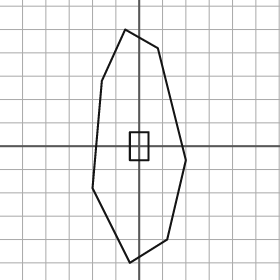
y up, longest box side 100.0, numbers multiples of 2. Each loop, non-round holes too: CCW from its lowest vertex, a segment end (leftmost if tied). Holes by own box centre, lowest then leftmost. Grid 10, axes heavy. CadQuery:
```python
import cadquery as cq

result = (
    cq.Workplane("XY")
    .moveTo(-4.0, -50.0)
    .lineTo(12.0, -40.0)
    .lineTo(20.0, -6.0)
    .lineTo(8.0, 42.0)
    .lineTo(-6.0, 50.0)
    .lineTo(-16.0, 28.0)
    .lineTo(-20.0, -18.0)
    .close()
    .moveTo(-4.0, -6.0)
    .lineTo(4.0, -6.0)
    .lineTo(4.0, 6.0)
    .lineTo(-4.0, 6.0)
    .close()
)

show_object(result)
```